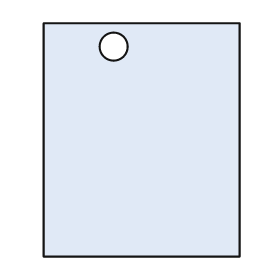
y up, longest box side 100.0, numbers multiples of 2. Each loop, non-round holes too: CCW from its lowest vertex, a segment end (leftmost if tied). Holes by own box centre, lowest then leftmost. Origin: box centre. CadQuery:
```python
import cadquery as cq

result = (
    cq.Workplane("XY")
    .moveTo(-42.0, -50.0)
    .lineTo(42.0, -50.0)
    .lineTo(42.0, 50.0)
    .lineTo(-42.0, 50.0)
    .close()
    .moveTo(-12.0, 40.0)
    .circle(6.0)
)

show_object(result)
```